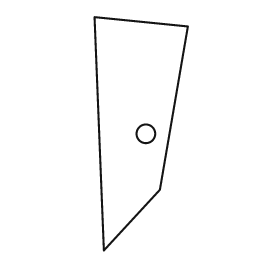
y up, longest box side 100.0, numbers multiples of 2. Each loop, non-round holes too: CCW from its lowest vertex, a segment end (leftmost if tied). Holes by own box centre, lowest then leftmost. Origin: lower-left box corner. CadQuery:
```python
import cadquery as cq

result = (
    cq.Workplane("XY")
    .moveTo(4.0, 0.0)
    .lineTo(28.0, 26.0)
    .lineTo(40.0, 96.0)
    .lineTo(0.0, 100.0)
    .close()
    .moveTo(22.0, 50.0)
    .circle(4.0)
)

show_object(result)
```